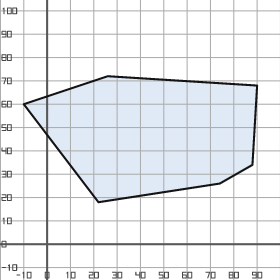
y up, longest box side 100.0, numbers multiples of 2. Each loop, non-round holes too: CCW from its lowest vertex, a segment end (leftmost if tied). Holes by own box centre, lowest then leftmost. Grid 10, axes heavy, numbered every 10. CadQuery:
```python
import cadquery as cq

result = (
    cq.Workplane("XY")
    .moveTo(22.0, 18.0)
    .lineTo(74.0, 26.0)
    .lineTo(88.0, 34.0)
    .lineTo(90.0, 68.0)
    .lineTo(26.0, 72.0)
    .lineTo(-10.0, 60.0)
    .close()
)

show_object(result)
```